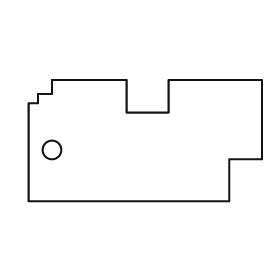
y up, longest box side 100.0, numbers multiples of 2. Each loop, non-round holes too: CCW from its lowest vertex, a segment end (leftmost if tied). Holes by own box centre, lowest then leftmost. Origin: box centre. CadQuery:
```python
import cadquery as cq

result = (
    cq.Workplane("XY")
    .moveTo(-50.0, -26.0)
    .lineTo(36.0, -26.0)
    .lineTo(36.0, -8.0)
    .lineTo(50.0, -8.0)
    .lineTo(50.0, 26.0)
    .lineTo(10.0, 26.0)
    .lineTo(10.0, 12.0)
    .lineTo(-8.0, 12.0)
    .lineTo(-8.0, 26.0)
    .lineTo(-40.0, 26.0)
    .lineTo(-40.0, 20.0)
    .lineTo(-46.0, 20.0)
    .lineTo(-46.0, 16.0)
    .lineTo(-50.0, 16.0)
    .close()
    .moveTo(-40.0, -4.0)
    .circle(4.0)
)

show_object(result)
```